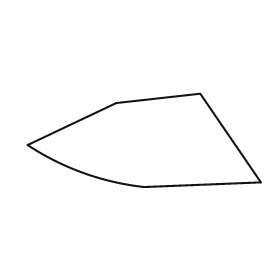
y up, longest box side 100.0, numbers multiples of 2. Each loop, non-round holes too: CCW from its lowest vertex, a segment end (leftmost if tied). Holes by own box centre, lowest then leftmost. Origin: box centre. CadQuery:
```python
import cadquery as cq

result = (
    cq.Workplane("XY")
    .moveTo(0.0, -20.0)
    .lineTo(50.0, -18.0)
    .lineTo(24.0, 20.0)
    .lineTo(-12.0, 16.0)
    .lineTo(-50.0, -2.0)
    .threePointArc((-26.0, -14.0), (0.0, -20.0))
    .close()
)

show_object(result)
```